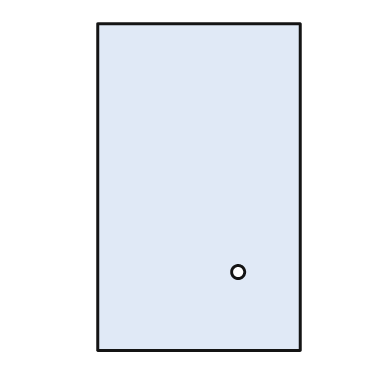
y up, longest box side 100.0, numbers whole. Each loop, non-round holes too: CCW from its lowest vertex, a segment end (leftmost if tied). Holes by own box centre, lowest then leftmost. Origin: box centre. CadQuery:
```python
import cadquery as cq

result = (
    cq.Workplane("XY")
    .moveTo(-31.0, -50.0)
    .lineTo(31.0, -50.0)
    .lineTo(31.0, 50.0)
    .lineTo(-31.0, 50.0)
    .close()
    .moveTo(12.0, -26.0)
    .circle(2.0)
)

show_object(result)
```